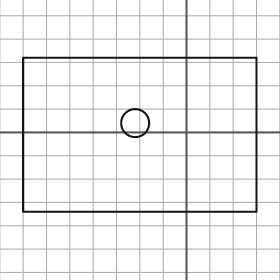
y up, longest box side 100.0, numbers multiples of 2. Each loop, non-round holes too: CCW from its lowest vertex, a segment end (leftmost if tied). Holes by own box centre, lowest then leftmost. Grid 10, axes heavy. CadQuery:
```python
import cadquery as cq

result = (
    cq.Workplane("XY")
    .moveTo(-70.0, -34.0)
    .lineTo(30.0, -34.0)
    .lineTo(30.0, 32.0)
    .lineTo(-70.0, 32.0)
    .close()
    .moveTo(-22.0, 4.0)
    .circle(6.0)
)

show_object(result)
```